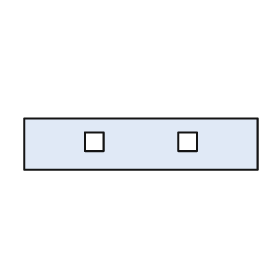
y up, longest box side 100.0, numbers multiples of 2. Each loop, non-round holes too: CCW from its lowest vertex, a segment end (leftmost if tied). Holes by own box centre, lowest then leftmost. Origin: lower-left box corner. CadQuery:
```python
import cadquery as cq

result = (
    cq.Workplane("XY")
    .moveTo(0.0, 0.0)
    .lineTo(100.0, 0.0)
    .lineTo(100.0, 22.0)
    .lineTo(0.0, 22.0)
    .close()
    .moveTo(26.0, 8.0)
    .lineTo(34.0, 8.0)
    .lineTo(34.0, 16.0)
    .lineTo(26.0, 16.0)
    .close()
    .moveTo(66.0, 8.0)
    .lineTo(74.0, 8.0)
    .lineTo(74.0, 16.0)
    .lineTo(66.0, 16.0)
    .close()
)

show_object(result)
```